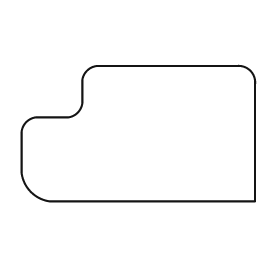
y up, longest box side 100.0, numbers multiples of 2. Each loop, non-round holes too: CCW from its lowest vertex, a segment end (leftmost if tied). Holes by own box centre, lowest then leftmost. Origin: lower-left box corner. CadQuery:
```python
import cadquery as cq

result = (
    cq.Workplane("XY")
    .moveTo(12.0, 0.0)
    .lineTo(100.0, 0.0)
    .lineTo(100.0, 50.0)
    .threePointArc((98.0, 56.0), (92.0, 58.0))
    .lineTo(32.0, 58.0)
    .threePointArc((28.0, 56.0), (26.0, 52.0))
    .lineTo(26.0, 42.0)
    .threePointArc((24.0, 38.0), (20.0, 36.0))
    .lineTo(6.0, 36.0)
    .threePointArc((2.0, 34.0), (0.0, 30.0))
    .lineTo(0.0, 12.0)
    .threePointArc((4.0, 4.0), (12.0, 0.0))
    .close()
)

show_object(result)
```